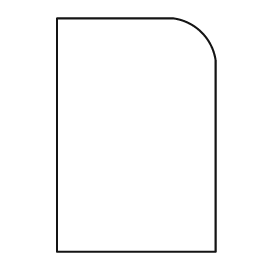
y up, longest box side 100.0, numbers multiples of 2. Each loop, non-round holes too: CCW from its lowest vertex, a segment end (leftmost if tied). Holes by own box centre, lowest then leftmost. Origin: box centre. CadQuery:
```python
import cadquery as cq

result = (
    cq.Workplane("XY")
    .moveTo(-34.0, -50.0)
    .lineTo(34.0, -50.0)
    .lineTo(34.0, 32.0)
    .threePointArc((28.0, 44.0), (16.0, 50.0))
    .lineTo(-34.0, 50.0)
    .close()
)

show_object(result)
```